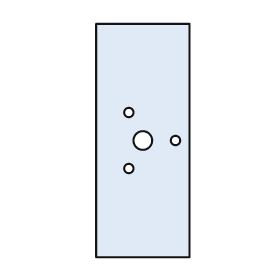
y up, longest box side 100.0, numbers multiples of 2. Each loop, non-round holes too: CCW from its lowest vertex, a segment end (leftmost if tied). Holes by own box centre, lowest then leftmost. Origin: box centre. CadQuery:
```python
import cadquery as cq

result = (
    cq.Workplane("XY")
    .moveTo(-20.0, -50.0)
    .lineTo(20.0, -50.0)
    .lineTo(20.0, 50.0)
    .lineTo(-20.0, 50.0)
    .close()
    .moveTo(-6.0, -12.0)
    .circle(2.0)
    .moveTo(0.0, 0.0)
    .circle(4.0)
    .moveTo(14.0, 0.0)
    .circle(2.0)
    .moveTo(-6.0, 12.0)
    .circle(2.0)
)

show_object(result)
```